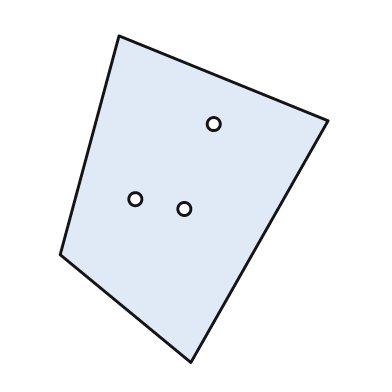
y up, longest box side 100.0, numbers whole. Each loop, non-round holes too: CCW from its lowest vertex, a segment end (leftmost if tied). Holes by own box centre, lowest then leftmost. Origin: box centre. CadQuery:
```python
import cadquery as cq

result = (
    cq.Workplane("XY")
    .moveTo(-1.0, -50.0)
    .lineTo(41.0, 24.0)
    .lineTo(-23.0, 50.0)
    .lineTo(-41.0, -17.0)
    .close()
    .moveTo(-3.0, -3.0)
    .circle(2.0)
    .moveTo(-18.0, 0.0)
    .circle(2.0)
    .moveTo(6.0, 23.0)
    .circle(2.0)
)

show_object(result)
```